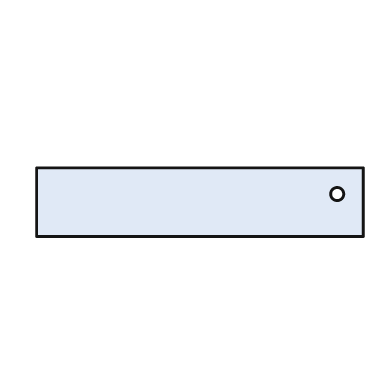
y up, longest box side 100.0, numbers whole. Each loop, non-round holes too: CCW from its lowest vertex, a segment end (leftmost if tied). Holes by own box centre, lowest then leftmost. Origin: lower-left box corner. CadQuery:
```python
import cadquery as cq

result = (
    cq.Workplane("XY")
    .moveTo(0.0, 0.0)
    .lineTo(100.0, 0.0)
    .lineTo(100.0, 21.0)
    .lineTo(0.0, 21.0)
    .close()
    .moveTo(92.0, 13.0)
    .circle(2.0)
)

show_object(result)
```